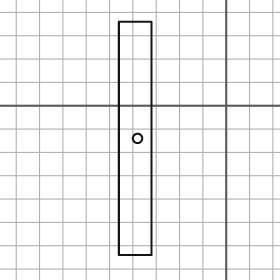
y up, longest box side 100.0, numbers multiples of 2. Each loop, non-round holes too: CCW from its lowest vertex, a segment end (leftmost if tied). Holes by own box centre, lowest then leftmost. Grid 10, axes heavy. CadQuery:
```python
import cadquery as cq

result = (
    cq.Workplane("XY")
    .moveTo(-46.0, -64.0)
    .lineTo(-32.0, -64.0)
    .lineTo(-32.0, 36.0)
    .lineTo(-46.0, 36.0)
    .close()
    .moveTo(-38.0, -14.0)
    .circle(2.0)
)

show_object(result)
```